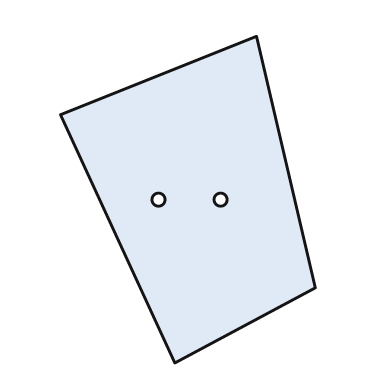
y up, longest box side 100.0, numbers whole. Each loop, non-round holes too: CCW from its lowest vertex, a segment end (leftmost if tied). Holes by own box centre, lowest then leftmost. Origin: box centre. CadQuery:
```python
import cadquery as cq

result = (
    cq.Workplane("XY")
    .moveTo(-4.0, -50.0)
    .lineTo(39.0, -27.0)
    .lineTo(21.0, 50.0)
    .lineTo(-39.0, 26.0)
    .close()
    .moveTo(-9.0, 0.0)
    .circle(2.0)
    .moveTo(10.0, 0.0)
    .circle(2.0)
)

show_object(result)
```